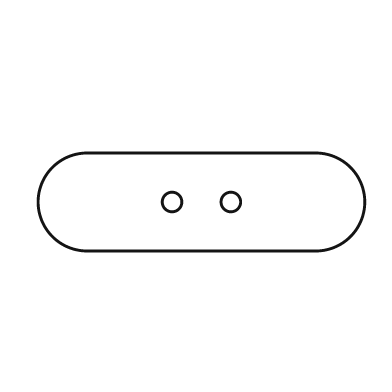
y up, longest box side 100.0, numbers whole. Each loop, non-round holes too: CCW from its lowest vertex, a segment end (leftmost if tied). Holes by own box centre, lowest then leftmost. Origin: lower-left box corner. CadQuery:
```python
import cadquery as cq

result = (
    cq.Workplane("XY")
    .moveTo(15.0, 0.0)
    .lineTo(85.0, 0.0)
    .threePointArc((100.0, 15.0), (85.0, 30.0))
    .lineTo(15.0, 30.0)
    .threePointArc((0.0, 15.0), (15.0, 0.0))
    .close()
    .moveTo(41.0, 15.0)
    .circle(3.0)
    .moveTo(59.0, 15.0)
    .circle(3.0)
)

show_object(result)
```